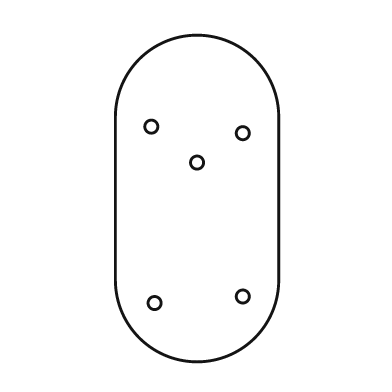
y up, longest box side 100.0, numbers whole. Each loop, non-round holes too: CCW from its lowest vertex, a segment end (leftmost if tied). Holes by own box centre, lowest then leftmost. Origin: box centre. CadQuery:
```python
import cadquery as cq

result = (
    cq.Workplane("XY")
    .moveTo(-25.0, -25.0)
    .threePointArc((0.0, -50.0), (25.0, -25.0))
    .lineTo(25.0, 25.0)
    .threePointArc((0.0, 50.0), (-25.0, 25.0))
    .close()
    .moveTo(-13.0, -32.0)
    .circle(2.0)
    .moveTo(14.0, -30.0)
    .circle(2.0)
    .moveTo(0.0, 11.0)
    .circle(2.0)
    .moveTo(14.0, 20.0)
    .circle(2.0)
    .moveTo(-14.0, 22.0)
    .circle(2.0)
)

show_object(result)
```